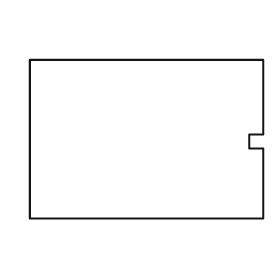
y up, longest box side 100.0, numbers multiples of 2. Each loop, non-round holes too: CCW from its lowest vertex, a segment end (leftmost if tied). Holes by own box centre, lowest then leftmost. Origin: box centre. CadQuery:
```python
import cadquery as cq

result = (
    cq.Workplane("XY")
    .moveTo(-50.0, -34.0)
    .lineTo(50.0, -34.0)
    .lineTo(50.0, -4.0)
    .lineTo(44.0, -4.0)
    .lineTo(44.0, 2.0)
    .lineTo(50.0, 2.0)
    .lineTo(50.0, 34.0)
    .lineTo(-50.0, 34.0)
    .close()
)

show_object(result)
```